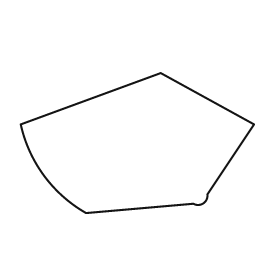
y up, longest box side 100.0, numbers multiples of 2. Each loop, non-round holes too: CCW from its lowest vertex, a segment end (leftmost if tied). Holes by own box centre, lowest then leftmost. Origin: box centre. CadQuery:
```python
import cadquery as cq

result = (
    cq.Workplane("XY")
    .moveTo(-22.0, -30.0)
    .lineTo(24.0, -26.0)
    .threePointArc((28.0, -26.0), (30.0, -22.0))
    .lineTo(50.0, 8.0)
    .lineTo(10.0, 30.0)
    .lineTo(-50.0, 8.0)
    .threePointArc((-40.0, -14.0), (-22.0, -30.0))
    .close()
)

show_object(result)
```